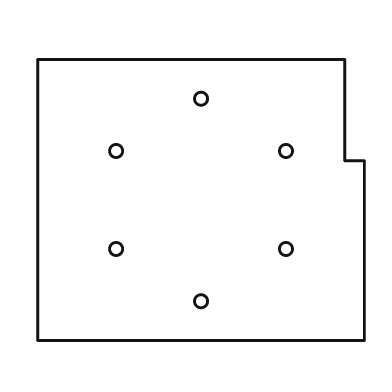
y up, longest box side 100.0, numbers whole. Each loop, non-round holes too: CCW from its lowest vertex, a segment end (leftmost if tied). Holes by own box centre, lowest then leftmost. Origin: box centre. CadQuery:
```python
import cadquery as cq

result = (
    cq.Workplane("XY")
    .moveTo(-50.0, -43.0)
    .lineTo(50.0, -43.0)
    .lineTo(50.0, 12.0)
    .lineTo(44.0, 12.0)
    .lineTo(44.0, 43.0)
    .lineTo(-50.0, 43.0)
    .close()
    .moveTo(0.0, -31.0)
    .circle(2.0)
    .moveTo(-26.0, -15.0)
    .circle(2.0)
    .moveTo(26.0, -15.0)
    .circle(2.0)
    .moveTo(-26.0, 15.0)
    .circle(2.0)
    .moveTo(26.0, 15.0)
    .circle(2.0)
    .moveTo(0.0, 31.0)
    .circle(2.0)
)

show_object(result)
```